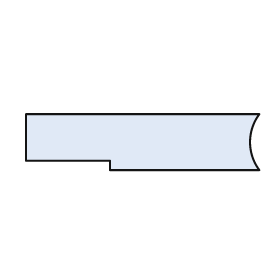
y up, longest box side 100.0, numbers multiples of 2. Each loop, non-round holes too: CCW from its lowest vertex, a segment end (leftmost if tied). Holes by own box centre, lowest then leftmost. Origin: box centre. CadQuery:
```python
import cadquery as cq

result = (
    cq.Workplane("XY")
    .moveTo(-14.0, -12.0)
    .lineTo(50.0, -12.0)
    .threePointArc((46.0, 0.0), (50.0, 12.0))
    .lineTo(-50.0, 12.0)
    .lineTo(-50.0, -8.0)
    .lineTo(-14.0, -8.0)
    .close()
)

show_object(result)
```